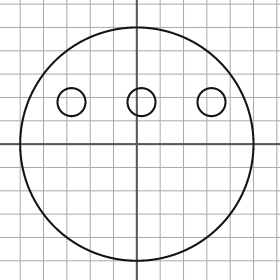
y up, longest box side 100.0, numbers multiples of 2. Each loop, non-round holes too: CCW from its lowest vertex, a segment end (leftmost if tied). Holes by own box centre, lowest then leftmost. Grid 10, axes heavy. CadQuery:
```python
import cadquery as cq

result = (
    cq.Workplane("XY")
    .moveTo(0.0, 0.0)
    .circle(50.0)
    .moveTo(-28.0, 18.0)
    .circle(6.0)
    .moveTo(2.0, 18.0)
    .circle(6.0)
    .moveTo(32.0, 18.0)
    .circle(6.0)
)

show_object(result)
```